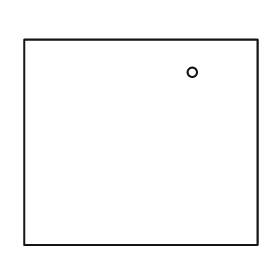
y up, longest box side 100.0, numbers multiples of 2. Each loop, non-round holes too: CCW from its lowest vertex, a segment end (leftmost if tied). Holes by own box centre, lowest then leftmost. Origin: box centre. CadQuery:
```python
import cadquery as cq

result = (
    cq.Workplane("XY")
    .moveTo(-50.0, -44.0)
    .lineTo(50.0, -44.0)
    .lineTo(50.0, 44.0)
    .lineTo(-50.0, 44.0)
    .close()
    .moveTo(22.0, 30.0)
    .circle(2.0)
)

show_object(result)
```